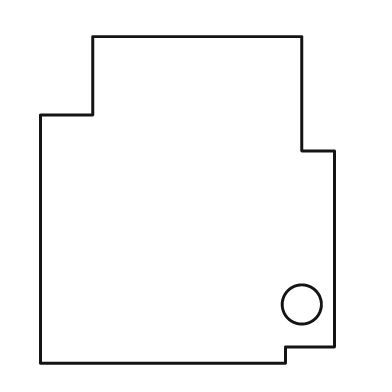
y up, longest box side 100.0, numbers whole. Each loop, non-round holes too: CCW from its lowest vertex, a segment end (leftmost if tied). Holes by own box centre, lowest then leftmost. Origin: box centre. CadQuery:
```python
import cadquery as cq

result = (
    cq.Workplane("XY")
    .moveTo(-45.0, -50.0)
    .lineTo(30.0, -50.0)
    .lineTo(30.0, -45.0)
    .lineTo(45.0, -45.0)
    .lineTo(45.0, 15.0)
    .lineTo(35.0, 15.0)
    .lineTo(35.0, 50.0)
    .lineTo(-29.0, 50.0)
    .lineTo(-29.0, 26.0)
    .lineTo(-45.0, 26.0)
    .close()
    .moveTo(35.0, -32.0)
    .circle(6.0)
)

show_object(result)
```